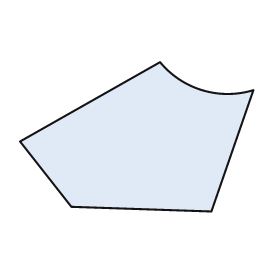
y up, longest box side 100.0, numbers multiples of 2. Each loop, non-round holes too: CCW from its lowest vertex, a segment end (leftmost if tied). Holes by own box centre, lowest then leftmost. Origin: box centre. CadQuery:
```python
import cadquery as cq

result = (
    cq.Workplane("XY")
    .moveTo(32.0, -32.0)
    .lineTo(50.0, 20.0)
    .threePointArc((28.0, 20.0), (10.0, 32.0))
    .lineTo(-50.0, -2.0)
    .lineTo(-28.0, -30.0)
    .close()
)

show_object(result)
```